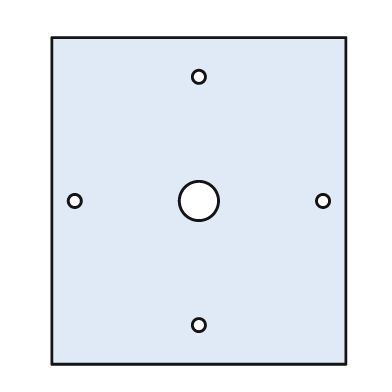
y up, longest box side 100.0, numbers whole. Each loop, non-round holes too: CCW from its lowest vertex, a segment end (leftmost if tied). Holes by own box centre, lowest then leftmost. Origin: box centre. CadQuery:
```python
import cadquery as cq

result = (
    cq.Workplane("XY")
    .moveTo(-45.0, -50.0)
    .lineTo(45.0, -50.0)
    .lineTo(45.0, 50.0)
    .lineTo(-45.0, 50.0)
    .close()
    .moveTo(0.0, -38.0)
    .circle(2.0)
    .moveTo(-38.0, 0.0)
    .circle(2.0)
    .moveTo(0.0, 0.0)
    .circle(6.0)
    .moveTo(38.0, 0.0)
    .circle(2.0)
    .moveTo(0.0, 38.0)
    .circle(2.0)
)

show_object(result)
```